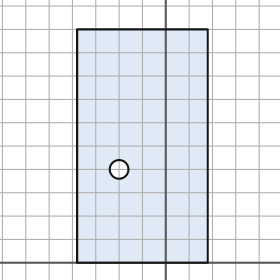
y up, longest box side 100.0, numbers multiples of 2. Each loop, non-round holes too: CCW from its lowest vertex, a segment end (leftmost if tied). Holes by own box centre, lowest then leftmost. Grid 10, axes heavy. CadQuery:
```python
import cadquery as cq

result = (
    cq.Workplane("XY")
    .moveTo(-38.0, 0.0)
    .lineTo(18.0, 0.0)
    .lineTo(18.0, 100.0)
    .lineTo(-38.0, 100.0)
    .close()
    .moveTo(-20.0, 40.0)
    .circle(4.0)
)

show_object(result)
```